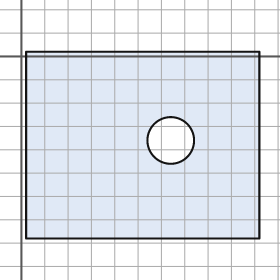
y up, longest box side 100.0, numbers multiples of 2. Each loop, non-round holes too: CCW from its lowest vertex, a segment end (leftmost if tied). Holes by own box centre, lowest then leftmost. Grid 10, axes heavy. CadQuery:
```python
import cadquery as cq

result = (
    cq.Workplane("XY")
    .moveTo(2.0, -78.0)
    .lineTo(102.0, -78.0)
    .lineTo(102.0, 2.0)
    .lineTo(2.0, 2.0)
    .close()
    .moveTo(64.0, -36.0)
    .circle(10.0)
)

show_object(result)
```